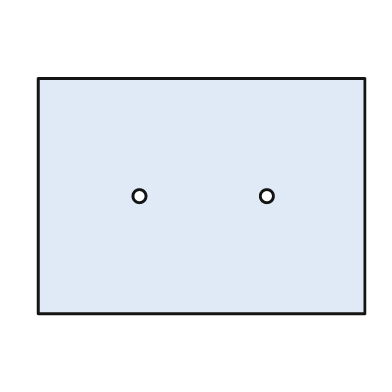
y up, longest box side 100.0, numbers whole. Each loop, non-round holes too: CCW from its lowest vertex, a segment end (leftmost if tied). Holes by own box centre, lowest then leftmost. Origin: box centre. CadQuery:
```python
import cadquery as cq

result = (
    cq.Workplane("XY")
    .moveTo(-50.0, -36.0)
    .lineTo(50.0, -36.0)
    .lineTo(50.0, 36.0)
    .lineTo(-50.0, 36.0)
    .close()
    .moveTo(-19.0, 0.0)
    .circle(2.0)
    .moveTo(20.0, 0.0)
    .circle(2.0)
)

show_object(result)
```